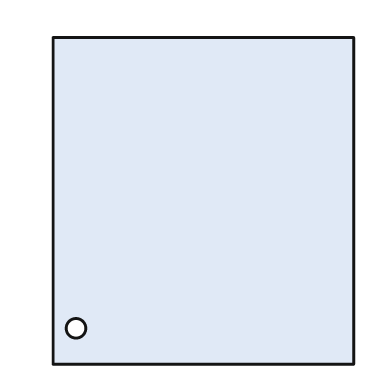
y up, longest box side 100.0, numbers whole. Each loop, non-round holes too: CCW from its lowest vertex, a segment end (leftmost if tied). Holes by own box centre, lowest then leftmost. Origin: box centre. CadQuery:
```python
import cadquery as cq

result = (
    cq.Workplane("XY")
    .moveTo(-46.0, -50.0)
    .lineTo(46.0, -50.0)
    .lineTo(46.0, 50.0)
    .lineTo(-46.0, 50.0)
    .close()
    .moveTo(-39.0, -39.0)
    .circle(3.0)
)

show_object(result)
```